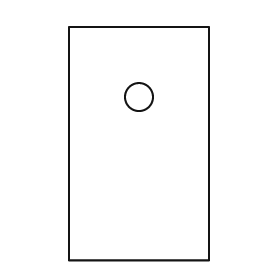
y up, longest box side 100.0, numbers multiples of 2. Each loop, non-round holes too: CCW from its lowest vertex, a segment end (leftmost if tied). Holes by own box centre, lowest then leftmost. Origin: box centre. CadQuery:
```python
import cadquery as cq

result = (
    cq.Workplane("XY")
    .moveTo(-30.0, -50.0)
    .lineTo(30.0, -50.0)
    .lineTo(30.0, 50.0)
    .lineTo(-30.0, 50.0)
    .close()
    .moveTo(0.0, 20.0)
    .circle(6.0)
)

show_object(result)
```